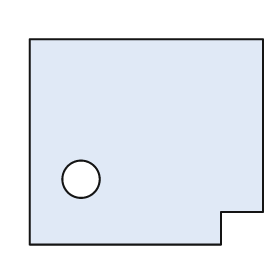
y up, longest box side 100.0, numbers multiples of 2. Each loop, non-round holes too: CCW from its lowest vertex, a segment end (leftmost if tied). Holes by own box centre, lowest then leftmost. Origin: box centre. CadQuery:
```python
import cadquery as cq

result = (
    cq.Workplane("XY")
    .moveTo(-50.0, -44.0)
    .lineTo(32.0, -44.0)
    .lineTo(32.0, -30.0)
    .lineTo(50.0, -30.0)
    .lineTo(50.0, 44.0)
    .lineTo(-50.0, 44.0)
    .close()
    .moveTo(-28.0, -16.0)
    .circle(8.0)
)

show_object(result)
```